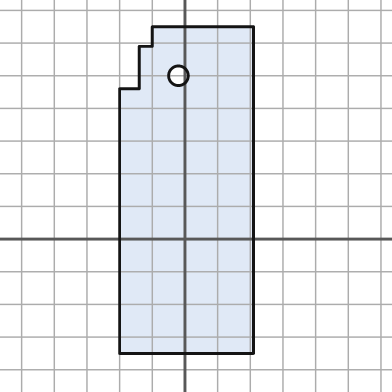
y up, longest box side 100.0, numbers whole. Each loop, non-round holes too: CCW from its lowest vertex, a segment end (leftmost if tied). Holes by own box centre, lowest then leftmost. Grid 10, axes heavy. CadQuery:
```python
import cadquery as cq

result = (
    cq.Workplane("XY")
    .moveTo(-20.0, -35.0)
    .lineTo(21.0, -35.0)
    .lineTo(21.0, 65.0)
    .lineTo(-10.0, 65.0)
    .lineTo(-10.0, 59.0)
    .lineTo(-14.0, 59.0)
    .lineTo(-14.0, 46.0)
    .lineTo(-20.0, 46.0)
    .close()
    .moveTo(-2.0, 50.0)
    .circle(3.0)
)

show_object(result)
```